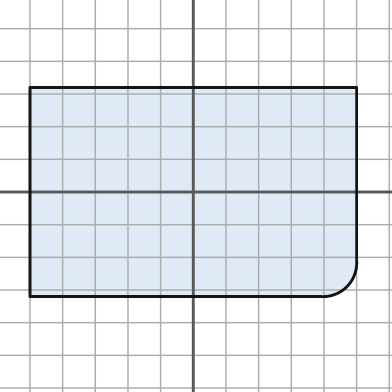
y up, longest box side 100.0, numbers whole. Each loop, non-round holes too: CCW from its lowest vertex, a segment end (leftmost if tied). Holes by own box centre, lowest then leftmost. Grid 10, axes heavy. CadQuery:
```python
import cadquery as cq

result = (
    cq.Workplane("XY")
    .moveTo(-50.0, -32.0)
    .lineTo(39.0, -32.0)
    .threePointArc((47.0, -29.0), (50.0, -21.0))
    .lineTo(50.0, 32.0)
    .lineTo(-50.0, 32.0)
    .close()
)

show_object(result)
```